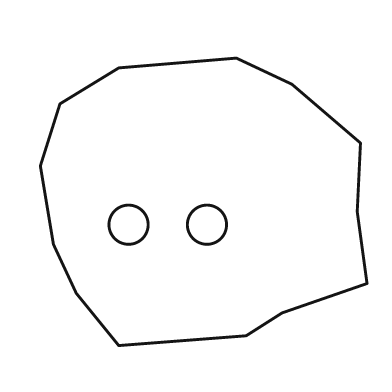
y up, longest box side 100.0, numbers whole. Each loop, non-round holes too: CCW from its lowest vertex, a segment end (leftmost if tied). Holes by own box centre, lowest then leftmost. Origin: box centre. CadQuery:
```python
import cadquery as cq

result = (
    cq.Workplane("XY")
    .moveTo(-26.0, -44.0)
    .lineTo(13.0, -41.0)
    .lineTo(24.0, -34.0)
    .lineTo(50.0, -25.0)
    .lineTo(47.0, -3.0)
    .lineTo(48.0, 18.0)
    .lineTo(27.0, 36.0)
    .lineTo(10.0, 44.0)
    .lineTo(-26.0, 41.0)
    .lineTo(-44.0, 30.0)
    .lineTo(-50.0, 11.0)
    .lineTo(-46.0, -13.0)
    .lineTo(-39.0, -28.0)
    .close()
    .moveTo(-23.0, -7.0)
    .circle(6.0)
    .moveTo(1.0, -7.0)
    .circle(6.0)
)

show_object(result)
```